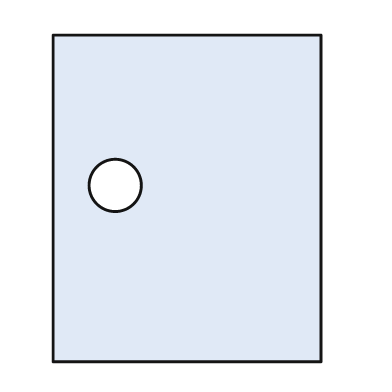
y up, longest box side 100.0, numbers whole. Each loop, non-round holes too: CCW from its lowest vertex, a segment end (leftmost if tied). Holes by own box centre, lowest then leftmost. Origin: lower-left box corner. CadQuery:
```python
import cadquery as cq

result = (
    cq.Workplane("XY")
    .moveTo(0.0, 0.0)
    .lineTo(82.0, 0.0)
    .lineTo(82.0, 100.0)
    .lineTo(0.0, 100.0)
    .close()
    .moveTo(19.0, 54.0)
    .circle(8.0)
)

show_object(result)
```